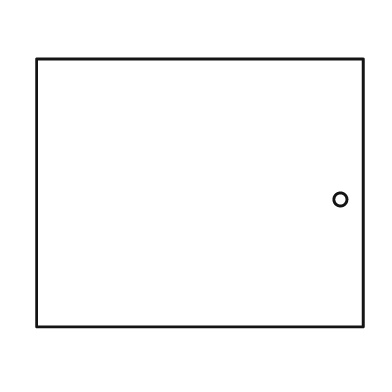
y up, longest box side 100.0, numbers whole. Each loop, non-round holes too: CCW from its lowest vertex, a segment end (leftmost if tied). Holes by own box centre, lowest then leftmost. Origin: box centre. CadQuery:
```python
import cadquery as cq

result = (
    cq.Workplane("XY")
    .moveTo(-50.0, -41.0)
    .lineTo(50.0, -41.0)
    .lineTo(50.0, 41.0)
    .lineTo(-50.0, 41.0)
    .close()
    .moveTo(43.0, -2.0)
    .circle(2.0)
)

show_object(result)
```